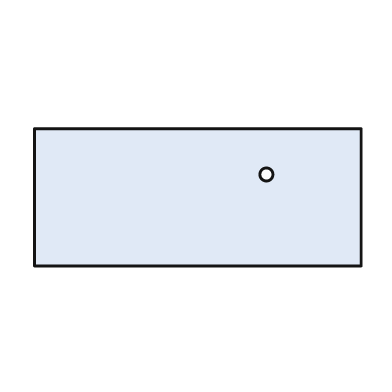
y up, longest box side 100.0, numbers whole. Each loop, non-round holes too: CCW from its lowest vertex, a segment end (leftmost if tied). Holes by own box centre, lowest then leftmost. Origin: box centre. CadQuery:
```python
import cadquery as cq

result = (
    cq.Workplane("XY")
    .moveTo(-50.0, -21.0)
    .lineTo(50.0, -21.0)
    .lineTo(50.0, 21.0)
    .lineTo(-50.0, 21.0)
    .close()
    .moveTo(21.0, 7.0)
    .circle(2.0)
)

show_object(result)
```